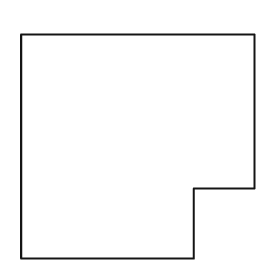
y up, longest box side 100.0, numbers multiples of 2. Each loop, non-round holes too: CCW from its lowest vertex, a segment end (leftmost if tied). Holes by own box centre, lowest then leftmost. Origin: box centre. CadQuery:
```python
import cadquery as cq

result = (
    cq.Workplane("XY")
    .moveTo(-50.0, -48.0)
    .lineTo(24.0, -48.0)
    .lineTo(24.0, -18.0)
    .lineTo(50.0, -18.0)
    .lineTo(50.0, 48.0)
    .lineTo(-50.0, 48.0)
    .close()
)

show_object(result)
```